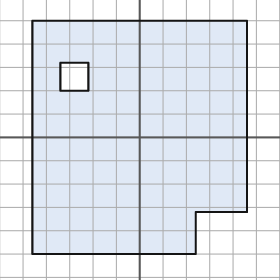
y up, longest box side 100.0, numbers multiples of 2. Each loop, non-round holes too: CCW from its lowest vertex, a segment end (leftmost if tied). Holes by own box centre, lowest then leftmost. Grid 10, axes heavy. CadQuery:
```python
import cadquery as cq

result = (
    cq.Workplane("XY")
    .moveTo(-46.0, -50.0)
    .lineTo(24.0, -50.0)
    .lineTo(24.0, -32.0)
    .lineTo(46.0, -32.0)
    .lineTo(46.0, 50.0)
    .lineTo(-46.0, 50.0)
    .close()
    .moveTo(-34.0, 20.0)
    .lineTo(-22.0, 20.0)
    .lineTo(-22.0, 32.0)
    .lineTo(-34.0, 32.0)
    .close()
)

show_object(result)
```